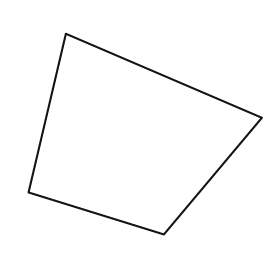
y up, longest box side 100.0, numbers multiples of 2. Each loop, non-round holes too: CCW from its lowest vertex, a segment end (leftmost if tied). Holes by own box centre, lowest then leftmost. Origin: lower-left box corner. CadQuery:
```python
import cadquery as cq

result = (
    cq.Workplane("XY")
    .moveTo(58.0, 0.0)
    .lineTo(100.0, 50.0)
    .lineTo(16.0, 86.0)
    .lineTo(0.0, 18.0)
    .close()
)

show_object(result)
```